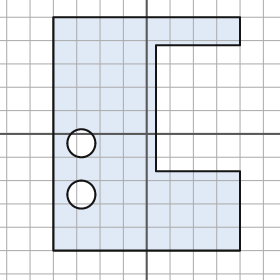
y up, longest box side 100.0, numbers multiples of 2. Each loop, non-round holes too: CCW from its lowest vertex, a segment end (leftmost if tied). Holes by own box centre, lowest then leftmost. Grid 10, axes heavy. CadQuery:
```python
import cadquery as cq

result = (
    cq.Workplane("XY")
    .moveTo(-40.0, -50.0)
    .lineTo(40.0, -50.0)
    .lineTo(40.0, -16.0)
    .lineTo(4.0, -16.0)
    .lineTo(4.0, 38.0)
    .lineTo(40.0, 38.0)
    .lineTo(40.0, 50.0)
    .lineTo(-40.0, 50.0)
    .close()
    .moveTo(-28.0, -26.0)
    .circle(6.0)
    .moveTo(-28.0, -4.0)
    .circle(6.0)
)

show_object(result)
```